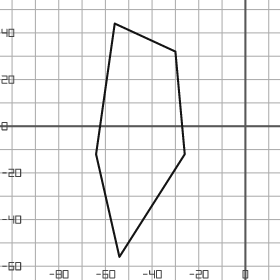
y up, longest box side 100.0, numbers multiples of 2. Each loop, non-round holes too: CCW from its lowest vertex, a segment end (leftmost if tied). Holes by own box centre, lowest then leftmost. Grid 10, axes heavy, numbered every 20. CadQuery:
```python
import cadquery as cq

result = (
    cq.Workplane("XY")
    .moveTo(-54.0, -56.0)
    .lineTo(-26.0, -12.0)
    .lineTo(-30.0, 32.0)
    .lineTo(-56.0, 44.0)
    .lineTo(-64.0, -12.0)
    .close()
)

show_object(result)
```